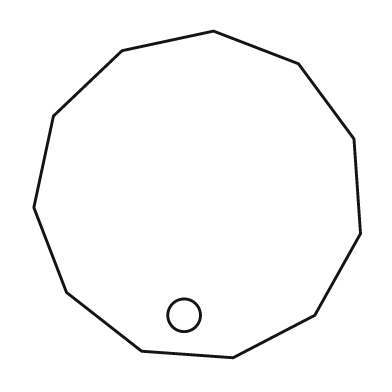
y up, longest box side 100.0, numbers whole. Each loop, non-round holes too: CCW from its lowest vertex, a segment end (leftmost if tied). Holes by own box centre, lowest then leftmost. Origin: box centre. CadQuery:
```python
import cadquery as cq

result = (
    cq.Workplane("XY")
    .moveTo(11.0, -50.0)
    .lineTo(36.0, -37.0)
    .lineTo(50.0, -12.0)
    .lineTo(48.0, 17.0)
    .lineTo(31.0, 40.0)
    .lineTo(5.0, 50.0)
    .lineTo(-23.0, 44.0)
    .lineTo(-44.0, 24.0)
    .lineTo(-50.0, -4.0)
    .lineTo(-40.0, -30.0)
    .lineTo(-17.0, -48.0)
    .close()
    .moveTo(-4.0, -37.0)
    .circle(5.0)
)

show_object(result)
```